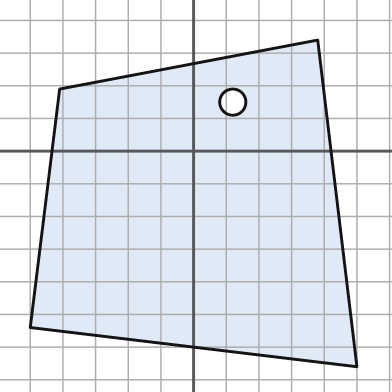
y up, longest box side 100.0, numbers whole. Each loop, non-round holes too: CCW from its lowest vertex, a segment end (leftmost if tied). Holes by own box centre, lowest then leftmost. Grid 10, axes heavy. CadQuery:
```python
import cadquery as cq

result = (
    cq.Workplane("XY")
    .moveTo(50.0, -66.0)
    .lineTo(38.0, 34.0)
    .lineTo(-41.0, 19.0)
    .lineTo(-50.0, -54.0)
    .close()
    .moveTo(12.0, 15.0)
    .circle(4.0)
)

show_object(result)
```